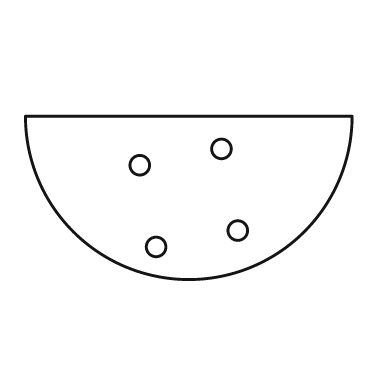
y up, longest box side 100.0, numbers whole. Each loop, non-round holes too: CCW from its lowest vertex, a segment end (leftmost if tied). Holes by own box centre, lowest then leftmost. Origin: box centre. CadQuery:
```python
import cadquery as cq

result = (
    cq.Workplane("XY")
    .moveTo(-50.0, 25.0)
    .threePointArc((0.0, -25.0), (50.0, 25.0))
    .close()
    .moveTo(-10.0, -15.0)
    .circle(3.0)
    .moveTo(15.0, -10.0)
    .circle(3.0)
    .moveTo(-15.0, 10.0)
    .circle(3.0)
    .moveTo(10.0, 15.0)
    .circle(3.0)
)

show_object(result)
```